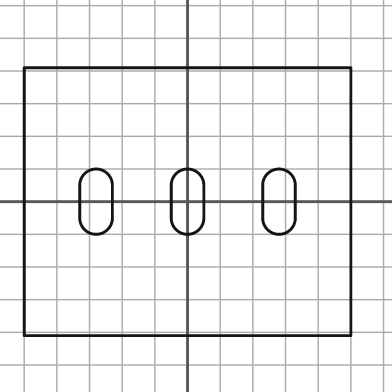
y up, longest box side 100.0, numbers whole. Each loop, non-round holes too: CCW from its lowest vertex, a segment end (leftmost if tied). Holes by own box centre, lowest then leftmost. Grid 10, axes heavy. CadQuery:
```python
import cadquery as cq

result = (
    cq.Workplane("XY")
    .moveTo(-50.0, -41.0)
    .lineTo(50.0, -41.0)
    .lineTo(50.0, 41.0)
    .lineTo(-50.0, 41.0)
    .close()
    .moveTo(-33.0, -5.0)
    .threePointArc((-28.0, -10.0), (-23.0, -5.0))
    .lineTo(-23.0, 5.0)
    .threePointArc((-28.0, 10.0), (-33.0, 5.0))
    .close()
    .moveTo(-5.0, -5.0)
    .threePointArc((0.0, -10.0), (5.0, -5.0))
    .lineTo(5.0, 5.0)
    .threePointArc((0.0, 10.0), (-5.0, 5.0))
    .close()
    .moveTo(23.0, -5.0)
    .threePointArc((28.0, -10.0), (33.0, -5.0))
    .lineTo(33.0, 5.0)
    .threePointArc((28.0, 10.0), (23.0, 5.0))
    .close()
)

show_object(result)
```